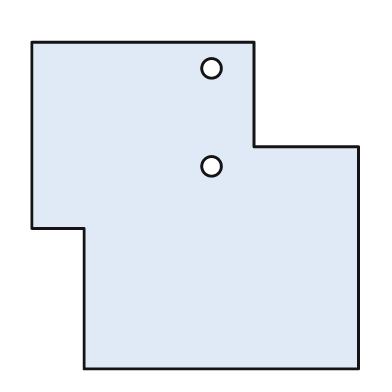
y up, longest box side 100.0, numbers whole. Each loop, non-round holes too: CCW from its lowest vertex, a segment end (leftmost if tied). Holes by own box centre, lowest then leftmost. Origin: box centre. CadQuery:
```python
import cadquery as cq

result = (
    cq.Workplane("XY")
    .moveTo(-34.0, -50.0)
    .lineTo(50.0, -50.0)
    .lineTo(50.0, 18.0)
    .lineTo(18.0, 18.0)
    .lineTo(18.0, 50.0)
    .lineTo(-50.0, 50.0)
    .lineTo(-50.0, -7.0)
    .lineTo(-34.0, -7.0)
    .close()
    .moveTo(5.0, 12.0)
    .circle(3.0)
    .moveTo(5.0, 42.0)
    .circle(3.0)
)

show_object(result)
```